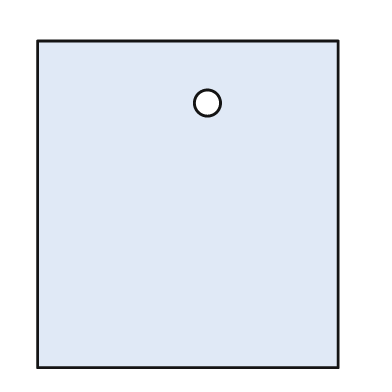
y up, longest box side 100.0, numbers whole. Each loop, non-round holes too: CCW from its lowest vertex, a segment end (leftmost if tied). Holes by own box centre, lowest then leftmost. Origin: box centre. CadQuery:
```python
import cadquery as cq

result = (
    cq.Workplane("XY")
    .moveTo(-46.0, -50.0)
    .lineTo(46.0, -50.0)
    .lineTo(46.0, 50.0)
    .lineTo(-46.0, 50.0)
    .close()
    .moveTo(6.0, 31.0)
    .circle(4.0)
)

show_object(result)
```